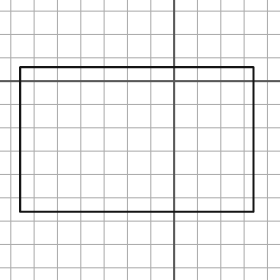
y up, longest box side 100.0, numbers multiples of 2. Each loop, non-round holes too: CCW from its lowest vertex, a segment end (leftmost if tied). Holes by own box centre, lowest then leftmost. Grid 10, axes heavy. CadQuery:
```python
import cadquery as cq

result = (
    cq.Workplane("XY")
    .moveTo(-66.0, -56.0)
    .lineTo(34.0, -56.0)
    .lineTo(34.0, 6.0)
    .lineTo(-66.0, 6.0)
    .close()
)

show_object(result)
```